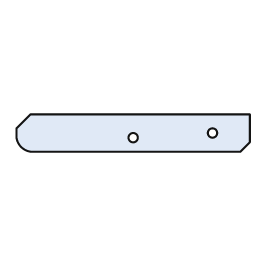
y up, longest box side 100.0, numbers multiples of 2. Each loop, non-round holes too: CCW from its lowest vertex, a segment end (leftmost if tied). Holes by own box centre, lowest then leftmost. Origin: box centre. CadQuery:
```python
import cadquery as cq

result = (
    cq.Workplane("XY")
    .moveTo(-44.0, -8.0)
    .lineTo(46.0, -8.0)
    .lineTo(50.0, -4.0)
    .lineTo(50.0, 8.0)
    .lineTo(-44.0, 8.0)
    .lineTo(-50.0, 2.0)
    .lineTo(-50.0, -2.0)
    .threePointArc((-48.0, -6.0), (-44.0, -8.0))
    .close()
    .moveTo(0.0, -2.0)
    .circle(2.0)
    .moveTo(34.0, 0.0)
    .circle(2.0)
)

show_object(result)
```